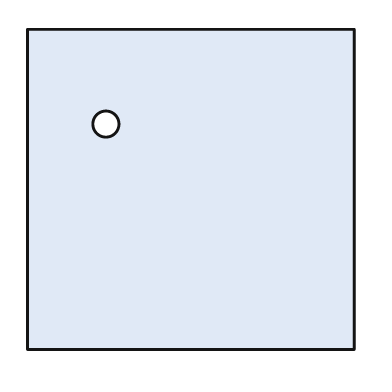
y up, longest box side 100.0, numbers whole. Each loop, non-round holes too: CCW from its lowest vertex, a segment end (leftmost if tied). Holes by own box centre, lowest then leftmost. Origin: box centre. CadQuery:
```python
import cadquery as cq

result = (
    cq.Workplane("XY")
    .moveTo(-50.0, -49.0)
    .lineTo(50.0, -49.0)
    .lineTo(50.0, 49.0)
    .lineTo(-50.0, 49.0)
    .close()
    .moveTo(-26.0, 20.0)
    .circle(4.0)
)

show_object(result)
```